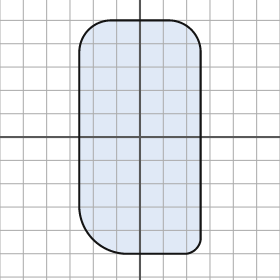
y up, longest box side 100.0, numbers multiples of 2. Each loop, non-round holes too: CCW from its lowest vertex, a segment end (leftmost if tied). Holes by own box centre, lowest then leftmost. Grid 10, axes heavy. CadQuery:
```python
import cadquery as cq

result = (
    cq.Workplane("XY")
    .moveTo(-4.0, -50.0)
    .lineTo(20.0, -50.0)
    .threePointArc((24.0, -48.0), (26.0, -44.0))
    .lineTo(26.0, 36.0)
    .threePointArc((22.0, 46.0), (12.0, 50.0))
    .lineTo(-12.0, 50.0)
    .threePointArc((-22.0, 46.0), (-26.0, 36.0))
    .lineTo(-26.0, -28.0)
    .threePointArc((-20.0, -44.0), (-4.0, -50.0))
    .close()
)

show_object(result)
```